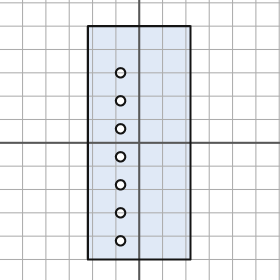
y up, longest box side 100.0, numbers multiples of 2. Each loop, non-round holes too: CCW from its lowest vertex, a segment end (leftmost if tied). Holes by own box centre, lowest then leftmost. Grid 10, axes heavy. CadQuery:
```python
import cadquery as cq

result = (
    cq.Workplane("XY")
    .moveTo(-22.0, -50.0)
    .lineTo(22.0, -50.0)
    .lineTo(22.0, 50.0)
    .lineTo(-22.0, 50.0)
    .close()
    .moveTo(-8.0, -42.0)
    .circle(2.0)
    .moveTo(-8.0, -30.0)
    .circle(2.0)
    .moveTo(-8.0, -18.0)
    .circle(2.0)
    .moveTo(-8.0, -6.0)
    .circle(2.0)
    .moveTo(-8.0, 6.0)
    .circle(2.0)
    .moveTo(-8.0, 18.0)
    .circle(2.0)
    .moveTo(-8.0, 30.0)
    .circle(2.0)
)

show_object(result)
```